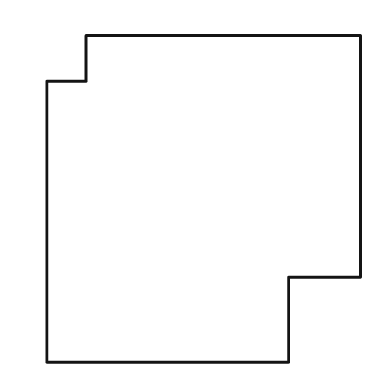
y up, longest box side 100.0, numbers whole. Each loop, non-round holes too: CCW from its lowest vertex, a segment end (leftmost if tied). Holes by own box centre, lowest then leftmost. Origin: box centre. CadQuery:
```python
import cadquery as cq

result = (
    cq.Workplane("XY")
    .moveTo(-48.0, -50.0)
    .lineTo(26.0, -50.0)
    .lineTo(26.0, -24.0)
    .lineTo(48.0, -24.0)
    .lineTo(48.0, 50.0)
    .lineTo(-36.0, 50.0)
    .lineTo(-36.0, 36.0)
    .lineTo(-48.0, 36.0)
    .close()
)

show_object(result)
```